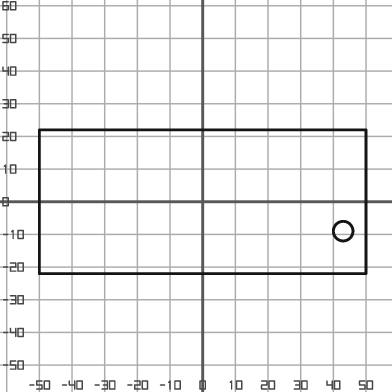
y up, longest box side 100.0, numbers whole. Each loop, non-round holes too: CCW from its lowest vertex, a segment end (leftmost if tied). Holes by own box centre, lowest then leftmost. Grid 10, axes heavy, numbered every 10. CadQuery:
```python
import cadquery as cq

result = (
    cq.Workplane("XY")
    .moveTo(-50.0, -22.0)
    .lineTo(50.0, -22.0)
    .lineTo(50.0, 22.0)
    .lineTo(-50.0, 22.0)
    .close()
    .moveTo(43.0, -9.0)
    .circle(3.0)
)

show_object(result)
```